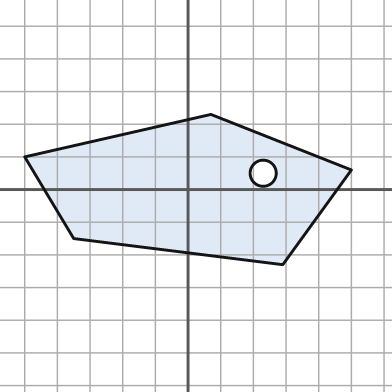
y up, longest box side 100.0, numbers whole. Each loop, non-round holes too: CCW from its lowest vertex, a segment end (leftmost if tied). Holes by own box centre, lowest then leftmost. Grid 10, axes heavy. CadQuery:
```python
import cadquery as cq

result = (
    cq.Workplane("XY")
    .moveTo(29.0, -23.0)
    .lineTo(50.0, 6.0)
    .lineTo(7.0, 23.0)
    .lineTo(-50.0, 10.0)
    .lineTo(-35.0, -15.0)
    .close()
    .moveTo(23.0, 5.0)
    .circle(4.0)
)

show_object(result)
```